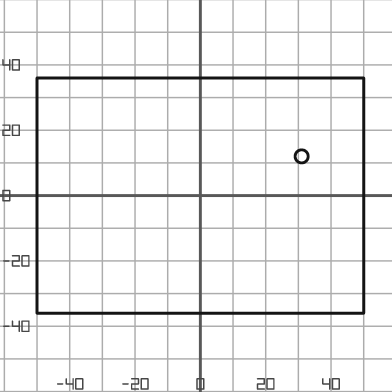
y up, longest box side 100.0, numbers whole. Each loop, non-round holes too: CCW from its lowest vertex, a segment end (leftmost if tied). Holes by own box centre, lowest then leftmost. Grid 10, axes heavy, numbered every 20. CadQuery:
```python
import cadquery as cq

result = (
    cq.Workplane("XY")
    .moveTo(-50.0, -36.0)
    .lineTo(50.0, -36.0)
    .lineTo(50.0, 36.0)
    .lineTo(-50.0, 36.0)
    .close()
    .moveTo(31.0, 12.0)
    .circle(2.0)
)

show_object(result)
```